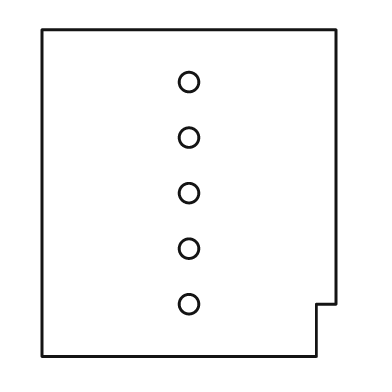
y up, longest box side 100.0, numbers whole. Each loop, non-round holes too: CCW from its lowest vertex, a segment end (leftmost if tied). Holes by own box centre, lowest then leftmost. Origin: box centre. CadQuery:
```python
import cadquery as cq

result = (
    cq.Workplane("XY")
    .moveTo(-45.0, -50.0)
    .lineTo(39.0, -50.0)
    .lineTo(39.0, -34.0)
    .lineTo(45.0, -34.0)
    .lineTo(45.0, 50.0)
    .lineTo(-45.0, 50.0)
    .close()
    .moveTo(0.0, -34.0)
    .circle(3.0)
    .moveTo(0.0, -17.0)
    .circle(3.0)
    .moveTo(0.0, 0.0)
    .circle(3.0)
    .moveTo(0.0, 17.0)
    .circle(3.0)
    .moveTo(0.0, 34.0)
    .circle(3.0)
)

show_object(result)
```